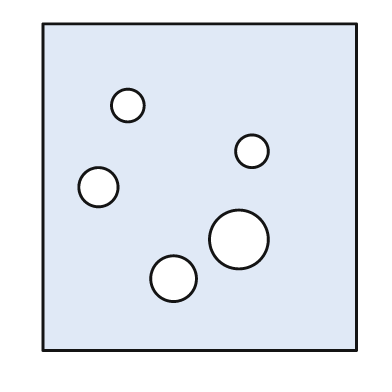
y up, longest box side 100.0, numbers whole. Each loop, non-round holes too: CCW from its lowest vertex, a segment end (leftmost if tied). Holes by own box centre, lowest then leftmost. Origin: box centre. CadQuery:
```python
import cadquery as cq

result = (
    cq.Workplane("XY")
    .moveTo(-48.0, -50.0)
    .lineTo(48.0, -50.0)
    .lineTo(48.0, 50.0)
    .lineTo(-48.0, 50.0)
    .close()
    .moveTo(-8.0, -28.0)
    .circle(7.0)
    .moveTo(12.0, -16.0)
    .circle(9.0)
    .moveTo(-31.0, 0.0)
    .circle(6.0)
    .moveTo(16.0, 11.0)
    .circle(5.0)
    .moveTo(-22.0, 25.0)
    .circle(5.0)
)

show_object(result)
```